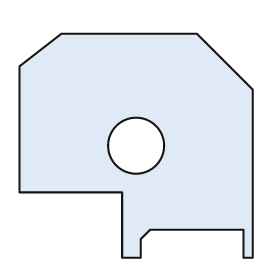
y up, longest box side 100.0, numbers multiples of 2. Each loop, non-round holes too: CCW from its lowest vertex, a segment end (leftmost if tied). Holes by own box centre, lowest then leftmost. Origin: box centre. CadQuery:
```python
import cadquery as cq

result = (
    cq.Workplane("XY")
    .moveTo(-6.0, -48.0)
    .lineTo(2.0, -48.0)
    .lineTo(2.0, -40.0)
    .lineTo(6.0, -36.0)
    .lineTo(46.0, -36.0)
    .lineTo(46.0, -48.0)
    .lineTo(50.0, -48.0)
    .lineTo(50.0, 24.0)
    .lineTo(26.0, 48.0)
    .lineTo(-32.0, 48.0)
    .lineTo(-50.0, 34.0)
    .lineTo(-50.0, -20.0)
    .lineTo(-6.0, -20.0)
    .close()
    .moveTo(0.0, 0.0)
    .circle(12.0)
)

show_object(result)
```